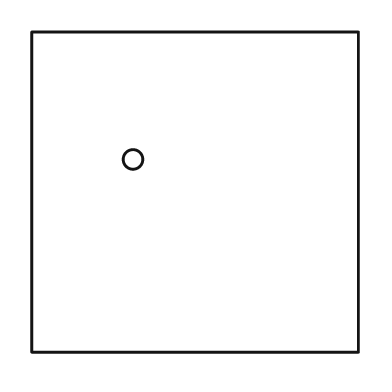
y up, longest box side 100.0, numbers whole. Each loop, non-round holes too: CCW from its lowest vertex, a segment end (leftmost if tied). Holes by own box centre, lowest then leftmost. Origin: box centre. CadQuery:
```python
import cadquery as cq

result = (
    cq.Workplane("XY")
    .moveTo(-50.0, -49.0)
    .lineTo(50.0, -49.0)
    .lineTo(50.0, 49.0)
    .lineTo(-50.0, 49.0)
    .close()
    .moveTo(-19.0, 10.0)
    .circle(3.0)
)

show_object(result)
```